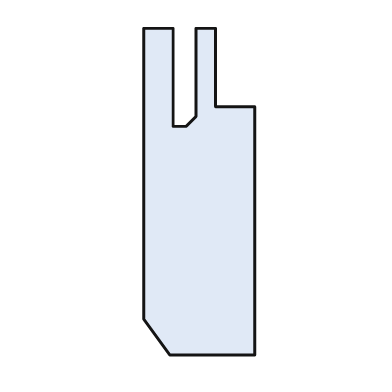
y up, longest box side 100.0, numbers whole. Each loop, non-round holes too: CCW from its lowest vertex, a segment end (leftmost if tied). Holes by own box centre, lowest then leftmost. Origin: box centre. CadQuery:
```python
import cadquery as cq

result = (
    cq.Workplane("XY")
    .moveTo(-9.0, -50.0)
    .lineTo(17.0, -50.0)
    .lineTo(17.0, 26.0)
    .lineTo(5.0, 26.0)
    .lineTo(5.0, 50.0)
    .lineTo(-1.0, 50.0)
    .lineTo(-1.0, 23.0)
    .lineTo(-4.0, 20.0)
    .lineTo(-8.0, 20.0)
    .lineTo(-8.0, 50.0)
    .lineTo(-17.0, 50.0)
    .lineTo(-17.0, -39.0)
    .close()
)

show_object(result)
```